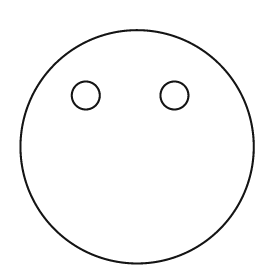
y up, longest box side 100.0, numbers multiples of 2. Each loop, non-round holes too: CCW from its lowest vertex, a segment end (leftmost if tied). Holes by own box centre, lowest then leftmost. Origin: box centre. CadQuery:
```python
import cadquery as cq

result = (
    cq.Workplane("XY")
    .moveTo(0.0, 0.0)
    .circle(50.0)
    .moveTo(-22.0, 22.0)
    .circle(6.0)
    .moveTo(16.0, 22.0)
    .circle(6.0)
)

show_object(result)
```